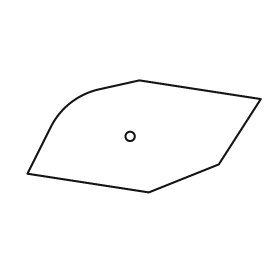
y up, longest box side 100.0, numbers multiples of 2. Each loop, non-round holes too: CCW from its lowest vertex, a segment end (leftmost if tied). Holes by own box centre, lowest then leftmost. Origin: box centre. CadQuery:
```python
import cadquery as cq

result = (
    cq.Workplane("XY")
    .moveTo(2.0, -24.0)
    .lineTo(32.0, -12.0)
    .lineTo(50.0, 16.0)
    .lineTo(-2.0, 24.0)
    .lineTo(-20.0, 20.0)
    .threePointArc((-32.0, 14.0), (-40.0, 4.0))
    .lineTo(-50.0, -16.0)
    .close()
    .moveTo(-6.0, 0.0)
    .circle(2.0)
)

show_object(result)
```